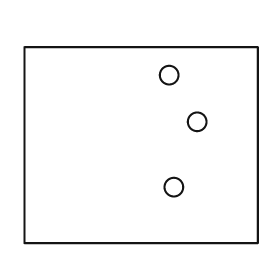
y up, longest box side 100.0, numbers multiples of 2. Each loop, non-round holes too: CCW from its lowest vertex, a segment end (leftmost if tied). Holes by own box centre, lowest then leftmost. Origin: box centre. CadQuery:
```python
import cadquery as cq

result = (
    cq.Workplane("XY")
    .moveTo(-50.0, -42.0)
    .lineTo(50.0, -42.0)
    .lineTo(50.0, 42.0)
    .lineTo(-50.0, 42.0)
    .close()
    .moveTo(14.0, -18.0)
    .circle(4.0)
    .moveTo(24.0, 10.0)
    .circle(4.0)
    .moveTo(12.0, 30.0)
    .circle(4.0)
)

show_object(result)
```